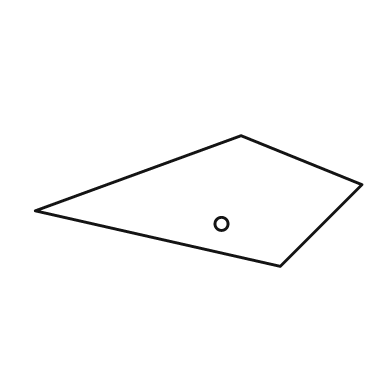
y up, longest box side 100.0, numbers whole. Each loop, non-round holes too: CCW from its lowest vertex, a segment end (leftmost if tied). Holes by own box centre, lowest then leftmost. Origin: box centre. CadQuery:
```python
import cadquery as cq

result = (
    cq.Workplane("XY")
    .moveTo(25.0, -20.0)
    .lineTo(50.0, 5.0)
    .lineTo(13.0, 20.0)
    .lineTo(-50.0, -3.0)
    .close()
    .moveTo(7.0, -7.0)
    .circle(2.0)
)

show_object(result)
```